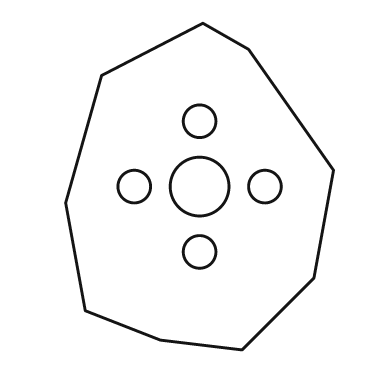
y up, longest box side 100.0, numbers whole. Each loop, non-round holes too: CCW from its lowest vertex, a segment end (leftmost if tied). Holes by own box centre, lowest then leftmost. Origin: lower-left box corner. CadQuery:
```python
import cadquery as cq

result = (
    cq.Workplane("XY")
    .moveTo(54.0, 0.0)
    .lineTo(76.0, 22.0)
    .lineTo(82.0, 55.0)
    .lineTo(56.0, 92.0)
    .lineTo(42.0, 100.0)
    .lineTo(11.0, 84.0)
    .lineTo(0.0, 45.0)
    .lineTo(6.0, 12.0)
    .lineTo(29.0, 3.0)
    .close()
    .moveTo(41.0, 30.0)
    .circle(5.0)
    .moveTo(21.0, 50.0)
    .circle(5.0)
    .moveTo(41.0, 50.0)
    .circle(9.0)
    .moveTo(61.0, 50.0)
    .circle(5.0)
    .moveTo(41.0, 70.0)
    .circle(5.0)
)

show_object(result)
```